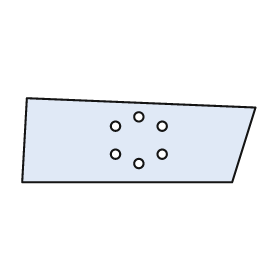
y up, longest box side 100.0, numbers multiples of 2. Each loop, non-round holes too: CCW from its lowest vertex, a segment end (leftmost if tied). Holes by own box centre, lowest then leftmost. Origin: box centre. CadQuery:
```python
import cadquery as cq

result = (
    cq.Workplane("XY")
    .moveTo(-50.0, -18.0)
    .lineTo(40.0, -18.0)
    .lineTo(50.0, 14.0)
    .lineTo(-48.0, 18.0)
    .close()
    .moveTo(0.0, -10.0)
    .circle(2.0)
    .moveTo(-10.0, -6.0)
    .circle(2.0)
    .moveTo(10.0, -6.0)
    .circle(2.0)
    .moveTo(-10.0, 6.0)
    .circle(2.0)
    .moveTo(10.0, 6.0)
    .circle(2.0)
    .moveTo(0.0, 10.0)
    .circle(2.0)
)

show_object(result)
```